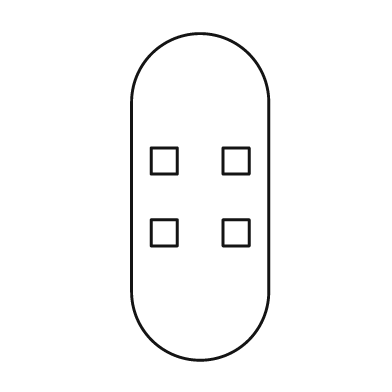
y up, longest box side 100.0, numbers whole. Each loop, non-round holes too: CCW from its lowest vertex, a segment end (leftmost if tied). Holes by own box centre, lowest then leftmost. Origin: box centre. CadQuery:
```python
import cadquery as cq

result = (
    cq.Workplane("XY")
    .moveTo(-21.0, -29.0)
    .threePointArc((0.0, -50.0), (21.0, -29.0))
    .lineTo(21.0, 29.0)
    .threePointArc((0.0, 50.0), (-21.0, 29.0))
    .close()
    .moveTo(-15.0, -15.0)
    .lineTo(-7.0, -15.0)
    .lineTo(-7.0, -7.0)
    .lineTo(-15.0, -7.0)
    .close()
    .moveTo(7.0, -15.0)
    .lineTo(15.0, -15.0)
    .lineTo(15.0, -7.0)
    .lineTo(7.0, -7.0)
    .close()
    .moveTo(-15.0, 7.0)
    .lineTo(-7.0, 7.0)
    .lineTo(-7.0, 15.0)
    .lineTo(-15.0, 15.0)
    .close()
    .moveTo(7.0, 7.0)
    .lineTo(15.0, 7.0)
    .lineTo(15.0, 15.0)
    .lineTo(7.0, 15.0)
    .close()
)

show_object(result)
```